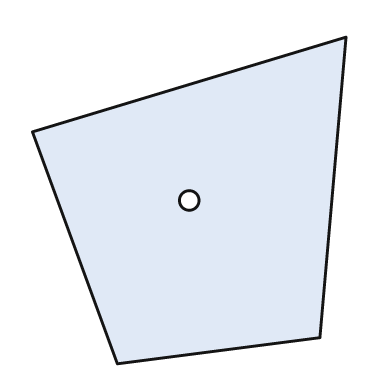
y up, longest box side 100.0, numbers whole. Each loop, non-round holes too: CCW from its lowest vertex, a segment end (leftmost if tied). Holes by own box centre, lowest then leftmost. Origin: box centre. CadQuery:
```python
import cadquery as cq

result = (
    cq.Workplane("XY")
    .moveTo(-22.0, -50.0)
    .lineTo(40.0, -42.0)
    .lineTo(48.0, 50.0)
    .lineTo(-48.0, 21.0)
    .close()
    .moveTo(0.0, 0.0)
    .circle(3.0)
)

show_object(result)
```